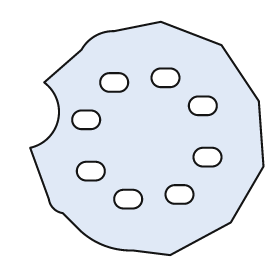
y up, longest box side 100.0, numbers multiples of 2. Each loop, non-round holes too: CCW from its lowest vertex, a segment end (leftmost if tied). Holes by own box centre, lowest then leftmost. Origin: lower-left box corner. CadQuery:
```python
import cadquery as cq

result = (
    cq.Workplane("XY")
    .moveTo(60.0, 0.0)
    .lineTo(86.0, 14.0)
    .lineTo(100.0, 38.0)
    .lineTo(98.0, 66.0)
    .lineTo(82.0, 90.0)
    .lineTo(56.0, 100.0)
    .lineTo(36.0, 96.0)
    .threePointArc((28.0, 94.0), (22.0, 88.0))
    .lineTo(6.0, 74.0)
    .threePointArc((12.0, 58.0), (0.0, 46.0))
    .lineTo(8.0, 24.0)
    .threePointArc((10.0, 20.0), (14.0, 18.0))
    .lineTo(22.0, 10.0)
    .threePointArc((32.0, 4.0), (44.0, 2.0))
    .close()
    .moveTo(40.0, 20.0)
    .lineTo(44.0, 20.0)
    .threePointArc((48.0, 24.0), (44.0, 28.0))
    .lineTo(40.0, 28.0)
    .threePointArc((36.0, 24.0), (40.0, 20.0))
    .close()
    .moveTo(62.0, 22.0)
    .lineTo(66.0, 22.0)
    .threePointArc((70.0, 26.0), (66.0, 30.0))
    .lineTo(62.0, 30.0)
    .threePointArc((58.0, 26.0), (62.0, 22.0))
    .close()
    .moveTo(24.0, 32.0)
    .lineTo(28.0, 32.0)
    .threePointArc((32.0, 36.0), (28.0, 40.0))
    .lineTo(24.0, 40.0)
    .threePointArc((20.0, 36.0), (24.0, 32.0))
    .close()
    .moveTo(74.0, 38.0)
    .lineTo(78.0, 38.0)
    .threePointArc((82.0, 42.0), (78.0, 46.0))
    .lineTo(74.0, 46.0)
    .threePointArc((70.0, 42.0), (74.0, 38.0))
    .close()
    .moveTo(22.0, 54.0)
    .lineTo(26.0, 54.0)
    .threePointArc((30.0, 58.0), (26.0, 62.0))
    .lineTo(22.0, 62.0)
    .threePointArc((18.0, 58.0), (22.0, 54.0))
    .close()
    .moveTo(72.0, 60.0)
    .lineTo(76.0, 60.0)
    .threePointArc((80.0, 64.0), (76.0, 68.0))
    .lineTo(72.0, 68.0)
    .threePointArc((68.0, 64.0), (72.0, 60.0))
    .close()
    .moveTo(34.0, 70.0)
    .lineTo(38.0, 70.0)
    .threePointArc((42.0, 74.0), (38.0, 78.0))
    .lineTo(34.0, 78.0)
    .threePointArc((30.0, 74.0), (34.0, 70.0))
    .close()
    .moveTo(56.0, 72.0)
    .lineTo(60.0, 72.0)
    .threePointArc((64.0, 76.0), (60.0, 80.0))
    .lineTo(56.0, 80.0)
    .threePointArc((52.0, 76.0), (56.0, 72.0))
    .close()
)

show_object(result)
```